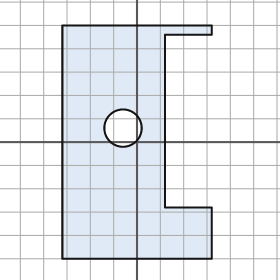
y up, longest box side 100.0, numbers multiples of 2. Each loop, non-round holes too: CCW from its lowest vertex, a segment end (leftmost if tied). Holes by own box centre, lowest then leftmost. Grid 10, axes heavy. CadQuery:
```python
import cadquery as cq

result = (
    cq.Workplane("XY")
    .moveTo(-32.0, -50.0)
    .lineTo(32.0, -50.0)
    .lineTo(32.0, -28.0)
    .lineTo(12.0, -28.0)
    .lineTo(12.0, 46.0)
    .lineTo(32.0, 46.0)
    .lineTo(32.0, 50.0)
    .lineTo(-32.0, 50.0)
    .close()
    .moveTo(-6.0, 6.0)
    .circle(8.0)
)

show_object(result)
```